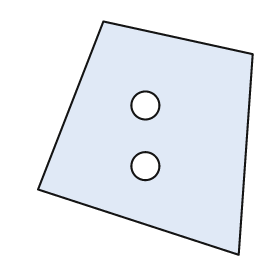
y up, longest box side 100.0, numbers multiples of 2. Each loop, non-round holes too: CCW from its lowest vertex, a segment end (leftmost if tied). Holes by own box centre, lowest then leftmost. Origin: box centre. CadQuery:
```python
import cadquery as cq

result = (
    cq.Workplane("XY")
    .moveTo(40.0, -50.0)
    .lineTo(46.0, 36.0)
    .lineTo(-18.0, 50.0)
    .lineTo(-46.0, -22.0)
    .close()
    .moveTo(0.0, -12.0)
    .circle(6.0)
    .moveTo(0.0, 14.0)
    .circle(6.0)
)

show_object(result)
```